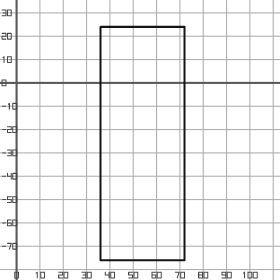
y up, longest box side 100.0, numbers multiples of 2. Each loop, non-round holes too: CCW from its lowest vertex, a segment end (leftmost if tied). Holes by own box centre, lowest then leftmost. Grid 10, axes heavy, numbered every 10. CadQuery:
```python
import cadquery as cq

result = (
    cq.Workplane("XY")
    .moveTo(36.0, -76.0)
    .lineTo(72.0, -76.0)
    .lineTo(72.0, 24.0)
    .lineTo(36.0, 24.0)
    .close()
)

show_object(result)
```